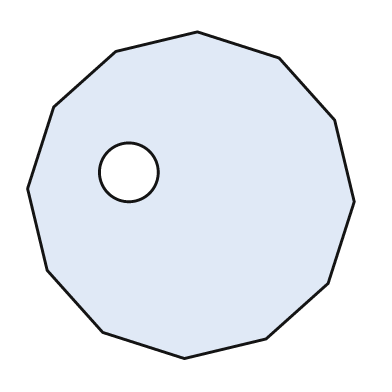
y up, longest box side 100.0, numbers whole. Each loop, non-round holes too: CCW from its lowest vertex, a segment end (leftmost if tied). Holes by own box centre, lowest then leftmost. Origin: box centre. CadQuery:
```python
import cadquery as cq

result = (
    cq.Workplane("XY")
    .moveTo(-2.0, -50.0)
    .lineTo(23.0, -44.0)
    .lineTo(42.0, -27.0)
    .lineTo(50.0, -2.0)
    .lineTo(44.0, 23.0)
    .lineTo(27.0, 42.0)
    .lineTo(2.0, 50.0)
    .lineTo(-23.0, 44.0)
    .lineTo(-42.0, 27.0)
    .lineTo(-50.0, 2.0)
    .lineTo(-44.0, -23.0)
    .lineTo(-27.0, -42.0)
    .close()
    .moveTo(-19.0, 7.0)
    .circle(9.0)
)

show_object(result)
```